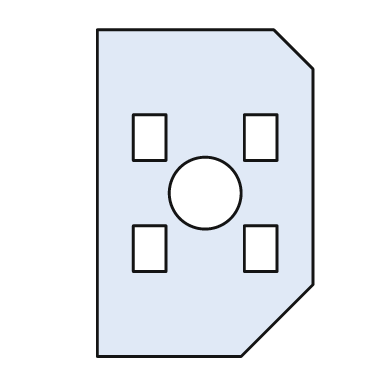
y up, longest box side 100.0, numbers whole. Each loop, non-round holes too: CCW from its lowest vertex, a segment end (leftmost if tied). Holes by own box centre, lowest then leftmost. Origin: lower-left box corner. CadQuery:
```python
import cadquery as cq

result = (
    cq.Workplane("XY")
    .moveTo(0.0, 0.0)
    .lineTo(44.0, 0.0)
    .lineTo(66.0, 22.0)
    .lineTo(66.0, 88.0)
    .lineTo(54.0, 100.0)
    .lineTo(0.0, 100.0)
    .close()
    .moveTo(11.0, 26.0)
    .lineTo(21.0, 26.0)
    .lineTo(21.0, 40.0)
    .lineTo(11.0, 40.0)
    .close()
    .moveTo(45.0, 26.0)
    .lineTo(55.0, 26.0)
    .lineTo(55.0, 40.0)
    .lineTo(45.0, 40.0)
    .close()
    .moveTo(33.0, 50.0)
    .circle(11.0)
    .moveTo(11.0, 60.0)
    .lineTo(21.0, 60.0)
    .lineTo(21.0, 74.0)
    .lineTo(11.0, 74.0)
    .close()
    .moveTo(45.0, 60.0)
    .lineTo(55.0, 60.0)
    .lineTo(55.0, 74.0)
    .lineTo(45.0, 74.0)
    .close()
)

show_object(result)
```